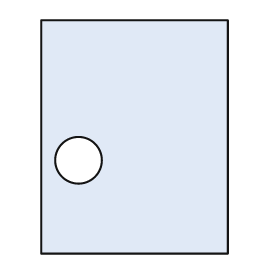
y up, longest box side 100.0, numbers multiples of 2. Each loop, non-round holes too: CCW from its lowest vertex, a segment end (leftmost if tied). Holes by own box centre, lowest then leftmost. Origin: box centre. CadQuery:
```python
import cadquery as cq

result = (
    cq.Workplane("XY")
    .moveTo(-40.0, -50.0)
    .lineTo(40.0, -50.0)
    .lineTo(40.0, 50.0)
    .lineTo(-40.0, 50.0)
    .close()
    .moveTo(-24.0, -10.0)
    .circle(10.0)
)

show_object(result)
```